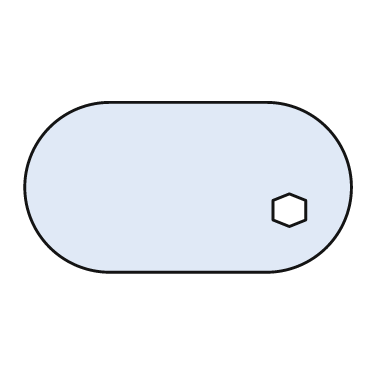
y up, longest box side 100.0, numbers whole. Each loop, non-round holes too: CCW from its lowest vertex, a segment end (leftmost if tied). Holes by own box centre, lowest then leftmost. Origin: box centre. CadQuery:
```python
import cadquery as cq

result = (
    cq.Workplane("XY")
    .moveTo(-24.0, -26.0)
    .lineTo(24.0, -26.0)
    .threePointArc((50.0, 0.0), (24.0, 26.0))
    .lineTo(-24.0, 26.0)
    .threePointArc((-50.0, 0.0), (-24.0, -26.0))
    .close()
    .moveTo(31.0, -12.0)
    .lineTo(36.0, -10.0)
    .lineTo(36.0, -4.0)
    .lineTo(31.0, -2.0)
    .lineTo(26.0, -4.0)
    .lineTo(26.0, -10.0)
    .close()
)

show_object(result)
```